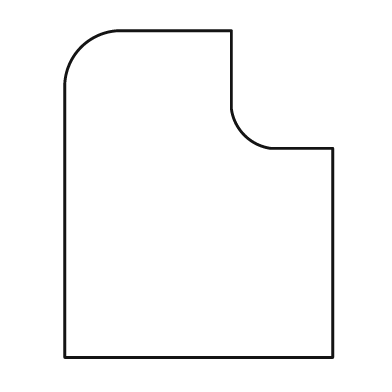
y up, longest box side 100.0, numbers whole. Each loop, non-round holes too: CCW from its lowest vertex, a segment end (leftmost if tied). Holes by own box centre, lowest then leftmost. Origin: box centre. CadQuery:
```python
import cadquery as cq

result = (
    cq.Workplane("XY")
    .moveTo(-41.0, -50.0)
    .lineTo(41.0, -50.0)
    .lineTo(41.0, 14.0)
    .lineTo(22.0, 14.0)
    .threePointArc((14.0, 18.0), (10.0, 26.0))
    .lineTo(10.0, 50.0)
    .lineTo(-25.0, 50.0)
    .threePointArc((-36.0, 45.0), (-41.0, 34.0))
    .close()
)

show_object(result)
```